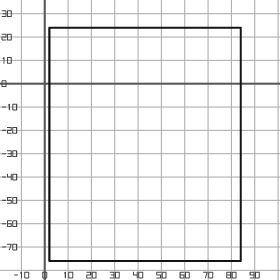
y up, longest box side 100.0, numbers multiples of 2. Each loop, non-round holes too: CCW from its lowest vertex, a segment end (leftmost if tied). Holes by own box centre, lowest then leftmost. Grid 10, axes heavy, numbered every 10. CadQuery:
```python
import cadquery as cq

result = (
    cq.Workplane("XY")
    .moveTo(2.0, -76.0)
    .lineTo(84.0, -76.0)
    .lineTo(84.0, 24.0)
    .lineTo(2.0, 24.0)
    .close()
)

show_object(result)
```